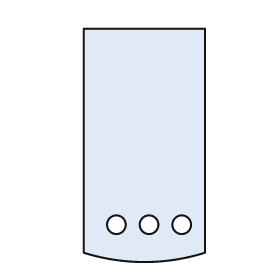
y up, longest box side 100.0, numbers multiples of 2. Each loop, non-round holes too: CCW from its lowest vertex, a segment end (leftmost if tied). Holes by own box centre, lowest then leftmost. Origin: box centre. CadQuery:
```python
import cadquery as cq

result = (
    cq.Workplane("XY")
    .moveTo(-26.0, -46.0)
    .threePointArc((0.0, -50.0), (26.0, -46.0))
    .lineTo(26.0, 50.0)
    .lineTo(-26.0, 50.0)
    .close()
    .moveTo(-12.0, -34.0)
    .circle(4.0)
    .moveTo(2.0, -34.0)
    .circle(4.0)
    .moveTo(16.0, -34.0)
    .circle(4.0)
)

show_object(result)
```